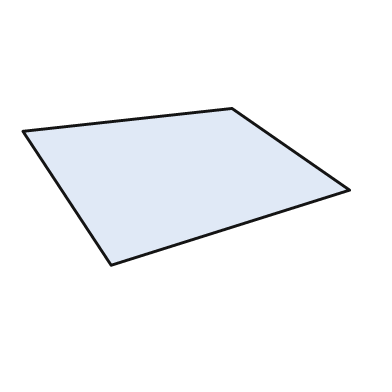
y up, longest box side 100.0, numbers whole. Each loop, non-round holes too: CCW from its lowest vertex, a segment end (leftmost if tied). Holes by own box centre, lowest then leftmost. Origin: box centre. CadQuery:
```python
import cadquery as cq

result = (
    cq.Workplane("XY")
    .moveTo(-23.0, -24.0)
    .lineTo(50.0, -1.0)
    .lineTo(14.0, 24.0)
    .lineTo(-50.0, 17.0)
    .close()
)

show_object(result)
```